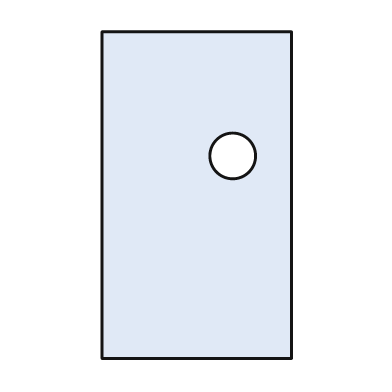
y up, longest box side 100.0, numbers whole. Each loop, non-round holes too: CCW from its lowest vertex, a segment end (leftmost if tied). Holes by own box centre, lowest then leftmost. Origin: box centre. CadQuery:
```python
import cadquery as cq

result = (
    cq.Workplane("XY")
    .moveTo(-29.0, -50.0)
    .lineTo(29.0, -50.0)
    .lineTo(29.0, 50.0)
    .lineTo(-29.0, 50.0)
    .close()
    .moveTo(11.0, 12.0)
    .circle(7.0)
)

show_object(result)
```